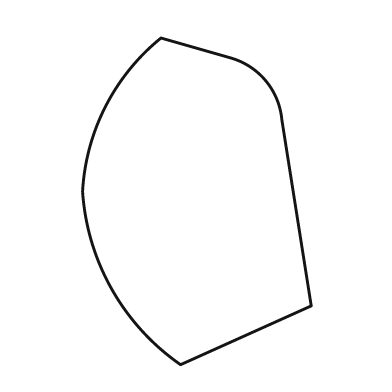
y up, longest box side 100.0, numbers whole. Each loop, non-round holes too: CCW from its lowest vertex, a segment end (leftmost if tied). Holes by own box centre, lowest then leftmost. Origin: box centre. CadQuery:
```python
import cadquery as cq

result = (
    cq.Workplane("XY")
    .moveTo(-5.0, -50.0)
    .lineTo(35.0, -32.0)
    .lineTo(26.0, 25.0)
    .threePointArc((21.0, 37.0), (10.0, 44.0))
    .lineTo(-11.0, 50.0)
    .threePointArc((-28.0, 29.0), (-35.0, 3.0))
    .threePointArc((-26.0, -27.0), (-5.0, -50.0))
    .close()
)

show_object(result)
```